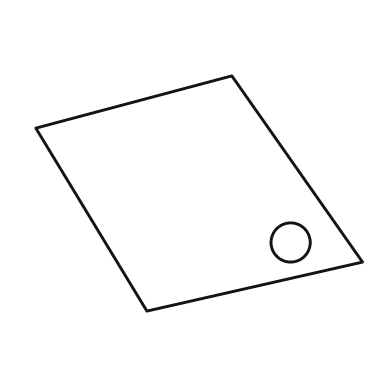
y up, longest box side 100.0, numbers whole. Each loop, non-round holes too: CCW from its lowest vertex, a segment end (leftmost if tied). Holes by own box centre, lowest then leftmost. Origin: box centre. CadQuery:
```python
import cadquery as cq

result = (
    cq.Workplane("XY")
    .moveTo(-16.0, -36.0)
    .lineTo(50.0, -21.0)
    .lineTo(10.0, 36.0)
    .lineTo(-50.0, 20.0)
    .close()
    .moveTo(28.0, -15.0)
    .circle(6.0)
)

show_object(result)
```